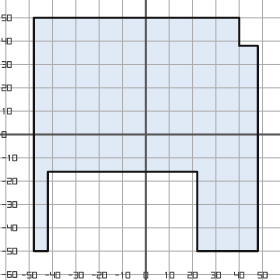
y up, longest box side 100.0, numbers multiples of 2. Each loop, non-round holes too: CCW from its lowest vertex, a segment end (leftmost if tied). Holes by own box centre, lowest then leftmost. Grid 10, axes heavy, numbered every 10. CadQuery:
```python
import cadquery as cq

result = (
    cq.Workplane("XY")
    .moveTo(-48.0, -50.0)
    .lineTo(-42.0, -50.0)
    .lineTo(-42.0, -16.0)
    .lineTo(22.0, -16.0)
    .lineTo(22.0, -50.0)
    .lineTo(48.0, -50.0)
    .lineTo(48.0, 38.0)
    .lineTo(40.0, 38.0)
    .lineTo(40.0, 50.0)
    .lineTo(-48.0, 50.0)
    .close()
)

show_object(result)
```